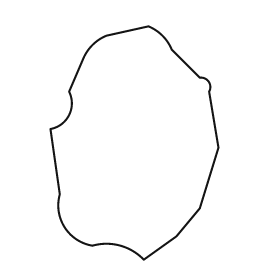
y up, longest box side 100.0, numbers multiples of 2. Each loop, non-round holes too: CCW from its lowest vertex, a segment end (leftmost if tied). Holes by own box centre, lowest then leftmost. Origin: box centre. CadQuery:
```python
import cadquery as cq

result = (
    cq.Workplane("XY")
    .moveTo(4.0, -50.0)
    .lineTo(18.0, -40.0)
    .lineTo(28.0, -28.0)
    .lineTo(36.0, -2.0)
    .lineTo(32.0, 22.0)
    .threePointArc((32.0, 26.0), (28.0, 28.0))
    .lineTo(16.0, 40.0)
    .threePointArc((12.0, 46.0), (6.0, 50.0))
    .lineTo(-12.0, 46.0)
    .threePointArc((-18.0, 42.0), (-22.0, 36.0))
    .lineTo(-28.0, 22.0)
    .threePointArc((-28.0, 12.0), (-36.0, 6.0))
    .lineTo(-32.0, -22.0)
    .threePointArc((-30.0, -36.0), (-18.0, -44.0))
    .threePointArc((-6.0, -44.0), (4.0, -50.0))
    .close()
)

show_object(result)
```